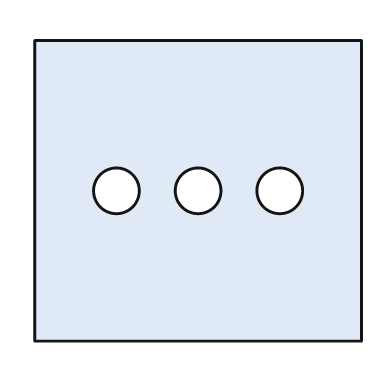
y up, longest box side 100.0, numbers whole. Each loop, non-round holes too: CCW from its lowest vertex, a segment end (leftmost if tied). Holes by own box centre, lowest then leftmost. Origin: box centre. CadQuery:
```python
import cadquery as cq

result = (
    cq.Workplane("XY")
    .moveTo(-50.0, -46.0)
    .lineTo(50.0, -46.0)
    .lineTo(50.0, 46.0)
    .lineTo(-50.0, 46.0)
    .close()
    .moveTo(-25.0, 0.0)
    .circle(7.0)
    .moveTo(0.0, 0.0)
    .circle(7.0)
    .moveTo(25.0, 0.0)
    .circle(7.0)
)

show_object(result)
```